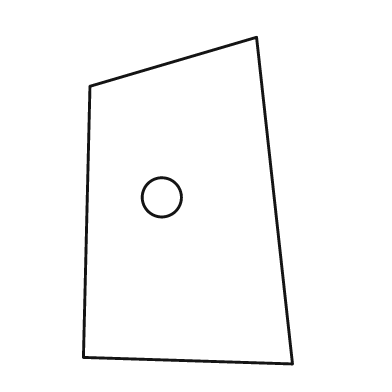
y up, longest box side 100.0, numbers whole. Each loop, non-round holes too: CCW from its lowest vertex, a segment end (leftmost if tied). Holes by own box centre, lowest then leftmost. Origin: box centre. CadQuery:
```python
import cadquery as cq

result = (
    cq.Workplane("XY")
    .moveTo(32.0, -50.0)
    .lineTo(21.0, 50.0)
    .lineTo(-30.0, 35.0)
    .lineTo(-32.0, -48.0)
    .close()
    .moveTo(-8.0, 1.0)
    .circle(6.0)
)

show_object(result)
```